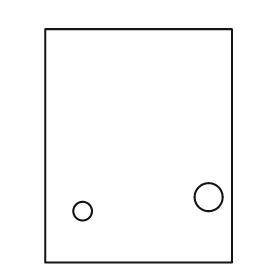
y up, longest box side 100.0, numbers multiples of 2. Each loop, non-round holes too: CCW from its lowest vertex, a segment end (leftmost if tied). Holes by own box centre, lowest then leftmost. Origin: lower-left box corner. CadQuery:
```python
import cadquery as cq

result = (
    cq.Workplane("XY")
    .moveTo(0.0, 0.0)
    .lineTo(80.0, 0.0)
    .lineTo(80.0, 100.0)
    .lineTo(0.0, 100.0)
    .close()
    .moveTo(16.0, 22.0)
    .circle(4.0)
    .moveTo(70.0, 28.0)
    .circle(6.0)
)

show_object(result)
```